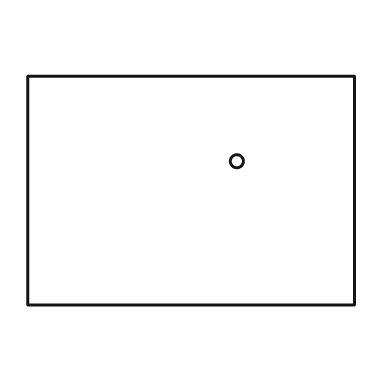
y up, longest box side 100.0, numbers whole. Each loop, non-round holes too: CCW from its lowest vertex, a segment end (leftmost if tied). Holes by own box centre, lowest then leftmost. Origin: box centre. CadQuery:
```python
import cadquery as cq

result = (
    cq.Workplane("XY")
    .moveTo(-50.0, -35.0)
    .lineTo(50.0, -35.0)
    .lineTo(50.0, 35.0)
    .lineTo(-50.0, 35.0)
    .close()
    .moveTo(14.0, 9.0)
    .circle(2.0)
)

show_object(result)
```